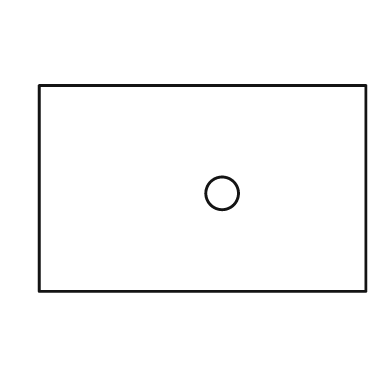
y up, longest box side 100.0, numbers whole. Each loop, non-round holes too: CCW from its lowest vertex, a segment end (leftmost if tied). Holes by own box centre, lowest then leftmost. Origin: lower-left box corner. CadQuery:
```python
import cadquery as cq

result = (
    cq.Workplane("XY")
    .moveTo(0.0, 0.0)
    .lineTo(100.0, 0.0)
    .lineTo(100.0, 63.0)
    .lineTo(0.0, 63.0)
    .close()
    .moveTo(56.0, 30.0)
    .circle(5.0)
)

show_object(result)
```